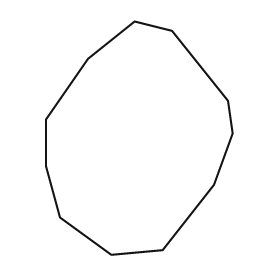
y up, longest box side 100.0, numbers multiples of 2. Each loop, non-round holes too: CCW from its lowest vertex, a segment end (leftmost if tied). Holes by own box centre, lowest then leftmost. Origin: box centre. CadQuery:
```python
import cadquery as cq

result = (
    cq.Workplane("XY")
    .moveTo(-12.0, -50.0)
    .lineTo(10.0, -48.0)
    .lineTo(32.0, -20.0)
    .lineTo(40.0, 2.0)
    .lineTo(38.0, 16.0)
    .lineTo(14.0, 46.0)
    .lineTo(-2.0, 50.0)
    .lineTo(-22.0, 34.0)
    .lineTo(-40.0, 8.0)
    .lineTo(-40.0, -12.0)
    .lineTo(-34.0, -34.0)
    .close()
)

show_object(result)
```